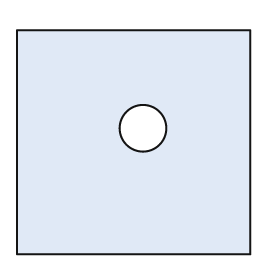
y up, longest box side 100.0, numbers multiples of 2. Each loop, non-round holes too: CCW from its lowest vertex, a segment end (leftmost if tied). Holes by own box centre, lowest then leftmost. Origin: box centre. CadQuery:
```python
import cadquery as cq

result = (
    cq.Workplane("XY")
    .moveTo(-50.0, -48.0)
    .lineTo(50.0, -48.0)
    .lineTo(50.0, 48.0)
    .lineTo(-50.0, 48.0)
    .close()
    .moveTo(4.0, 6.0)
    .circle(10.0)
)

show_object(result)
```